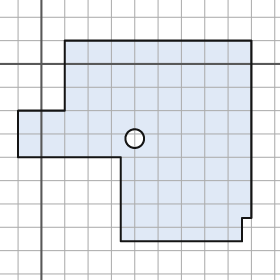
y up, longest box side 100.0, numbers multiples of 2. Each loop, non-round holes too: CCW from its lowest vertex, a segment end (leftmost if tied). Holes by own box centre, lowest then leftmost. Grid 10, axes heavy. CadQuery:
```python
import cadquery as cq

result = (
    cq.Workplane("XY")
    .moveTo(34.0, -76.0)
    .lineTo(86.0, -76.0)
    .lineTo(86.0, -66.0)
    .lineTo(90.0, -66.0)
    .lineTo(90.0, 10.0)
    .lineTo(10.0, 10.0)
    .lineTo(10.0, -20.0)
    .lineTo(-10.0, -20.0)
    .lineTo(-10.0, -40.0)
    .lineTo(34.0, -40.0)
    .close()
    .moveTo(40.0, -32.0)
    .circle(4.0)
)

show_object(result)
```